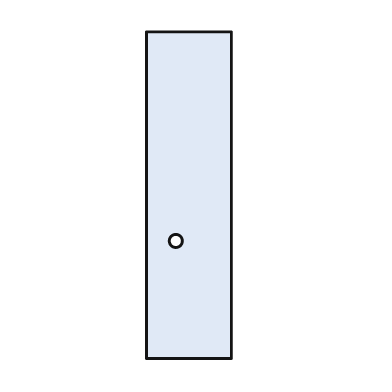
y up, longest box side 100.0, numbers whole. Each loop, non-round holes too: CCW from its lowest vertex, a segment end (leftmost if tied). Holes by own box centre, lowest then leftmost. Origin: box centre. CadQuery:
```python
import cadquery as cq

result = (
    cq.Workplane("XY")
    .moveTo(-13.0, -50.0)
    .lineTo(13.0, -50.0)
    .lineTo(13.0, 50.0)
    .lineTo(-13.0, 50.0)
    .close()
    .moveTo(-4.0, -14.0)
    .circle(2.0)
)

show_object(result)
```